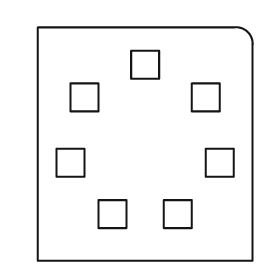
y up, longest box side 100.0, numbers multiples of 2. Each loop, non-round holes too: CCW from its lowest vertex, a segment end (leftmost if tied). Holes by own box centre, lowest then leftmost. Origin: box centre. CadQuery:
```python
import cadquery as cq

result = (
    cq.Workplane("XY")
    .moveTo(-46.0, -50.0)
    .lineTo(46.0, -50.0)
    .lineTo(46.0, 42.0)
    .threePointArc((44.0, 48.0), (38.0, 50.0))
    .lineTo(-46.0, 50.0)
    .close()
    .moveTo(-20.0, -36.0)
    .lineTo(-8.0, -36.0)
    .lineTo(-8.0, -24.0)
    .lineTo(-20.0, -24.0)
    .close()
    .moveTo(8.0, -36.0)
    .lineTo(20.0, -36.0)
    .lineTo(20.0, -24.0)
    .lineTo(8.0, -24.0)
    .close()
    .moveTo(-38.0, -14.0)
    .lineTo(-26.0, -14.0)
    .lineTo(-26.0, -2.0)
    .lineTo(-38.0, -2.0)
    .close()
    .moveTo(26.0, -14.0)
    .lineTo(38.0, -14.0)
    .lineTo(38.0, -2.0)
    .lineTo(26.0, -2.0)
    .close()
    .moveTo(-32.0, 14.0)
    .lineTo(-20.0, 14.0)
    .lineTo(-20.0, 26.0)
    .lineTo(-32.0, 26.0)
    .close()
    .moveTo(20.0, 14.0)
    .lineTo(32.0, 14.0)
    .lineTo(32.0, 26.0)
    .lineTo(20.0, 26.0)
    .close()
    .moveTo(-6.0, 28.0)
    .lineTo(6.0, 28.0)
    .lineTo(6.0, 40.0)
    .lineTo(-6.0, 40.0)
    .close()
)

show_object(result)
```